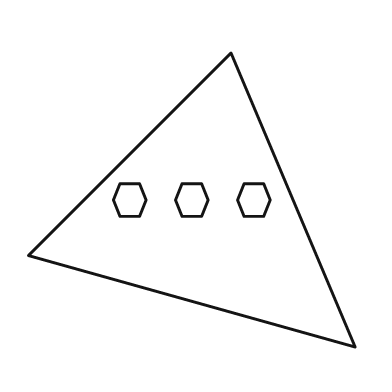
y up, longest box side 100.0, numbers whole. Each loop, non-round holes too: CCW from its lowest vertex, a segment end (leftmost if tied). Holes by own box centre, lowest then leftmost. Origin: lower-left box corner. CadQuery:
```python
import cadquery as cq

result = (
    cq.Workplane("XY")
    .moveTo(100.0, 0.0)
    .lineTo(62.0, 90.0)
    .lineTo(0.0, 28.0)
    .close()
    .moveTo(28.0, 40.0)
    .lineTo(34.0, 40.0)
    .lineTo(36.0, 45.0)
    .lineTo(34.0, 50.0)
    .lineTo(28.0, 50.0)
    .lineTo(26.0, 45.0)
    .close()
    .moveTo(47.0, 40.0)
    .lineTo(53.0, 40.0)
    .lineTo(55.0, 45.0)
    .lineTo(53.0, 50.0)
    .lineTo(47.0, 50.0)
    .lineTo(45.0, 45.0)
    .close()
    .moveTo(66.0, 40.0)
    .lineTo(72.0, 40.0)
    .lineTo(74.0, 45.0)
    .lineTo(72.0, 50.0)
    .lineTo(66.0, 50.0)
    .lineTo(64.0, 45.0)
    .close()
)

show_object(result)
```